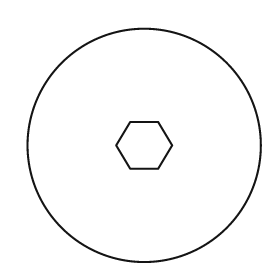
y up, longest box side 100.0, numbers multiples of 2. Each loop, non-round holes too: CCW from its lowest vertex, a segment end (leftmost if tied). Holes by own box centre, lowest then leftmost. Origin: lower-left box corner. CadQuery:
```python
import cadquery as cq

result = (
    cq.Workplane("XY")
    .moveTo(50.0, 50.0)
    .circle(50.0)
    .moveTo(44.0, 40.0)
    .lineTo(56.0, 40.0)
    .lineTo(62.0, 50.0)
    .lineTo(56.0, 60.0)
    .lineTo(44.0, 60.0)
    .lineTo(38.0, 50.0)
    .close()
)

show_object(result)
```